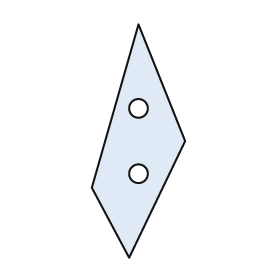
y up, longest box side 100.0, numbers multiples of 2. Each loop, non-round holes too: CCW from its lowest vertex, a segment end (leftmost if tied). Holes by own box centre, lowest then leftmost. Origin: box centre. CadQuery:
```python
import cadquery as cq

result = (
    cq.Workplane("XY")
    .moveTo(-4.0, -50.0)
    .lineTo(20.0, 0.0)
    .lineTo(0.0, 50.0)
    .lineTo(-20.0, -20.0)
    .close()
    .moveTo(0.0, -14.0)
    .circle(4.0)
    .moveTo(0.0, 14.0)
    .circle(4.0)
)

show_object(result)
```